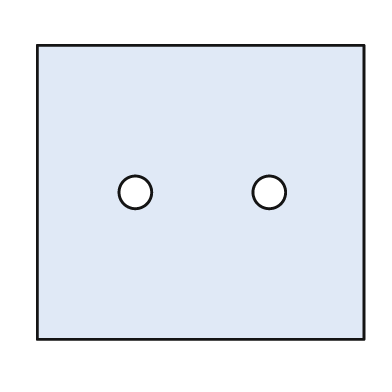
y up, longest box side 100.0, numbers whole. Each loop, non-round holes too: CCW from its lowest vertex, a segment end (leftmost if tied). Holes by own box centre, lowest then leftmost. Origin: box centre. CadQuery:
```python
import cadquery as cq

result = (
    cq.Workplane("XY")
    .moveTo(-50.0, -45.0)
    .lineTo(50.0, -45.0)
    .lineTo(50.0, 45.0)
    .lineTo(-50.0, 45.0)
    .close()
    .moveTo(-20.0, 0.0)
    .circle(5.0)
    .moveTo(21.0, 0.0)
    .circle(5.0)
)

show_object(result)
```